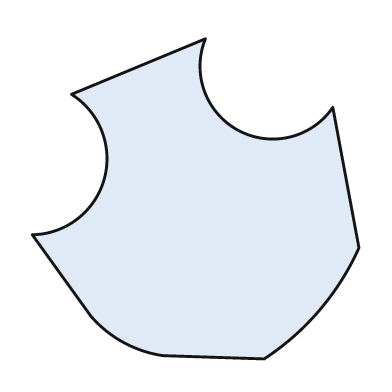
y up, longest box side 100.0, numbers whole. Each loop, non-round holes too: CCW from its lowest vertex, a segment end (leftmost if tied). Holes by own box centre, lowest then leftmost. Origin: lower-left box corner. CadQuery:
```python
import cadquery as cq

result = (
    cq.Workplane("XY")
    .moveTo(71.0, 0.0)
    .threePointArc((88.0, 15.0), (100.0, 34.0))
    .lineTo(92.0, 77.0)
    .threePointArc((63.0, 70.0), (53.0, 98.0))
    .lineTo(12.0, 81.0)
    .threePointArc((22.0, 55.0), (0.0, 38.0))
    .lineTo(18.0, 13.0)
    .threePointArc((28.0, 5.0), (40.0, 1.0))
    .close()
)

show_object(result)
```